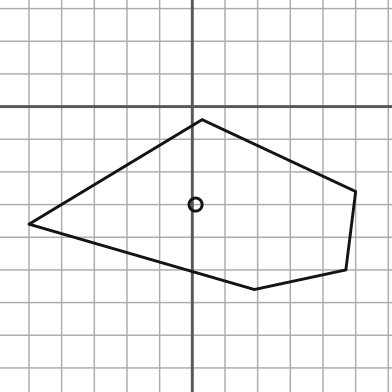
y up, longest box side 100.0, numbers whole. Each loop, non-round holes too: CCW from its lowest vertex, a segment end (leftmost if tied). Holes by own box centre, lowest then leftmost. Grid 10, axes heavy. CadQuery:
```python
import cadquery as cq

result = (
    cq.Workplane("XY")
    .moveTo(19.0, -56.0)
    .lineTo(47.0, -50.0)
    .lineTo(50.0, -26.0)
    .lineTo(3.0, -4.0)
    .lineTo(-50.0, -36.0)
    .close()
    .moveTo(1.0, -30.0)
    .circle(2.0)
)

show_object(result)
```